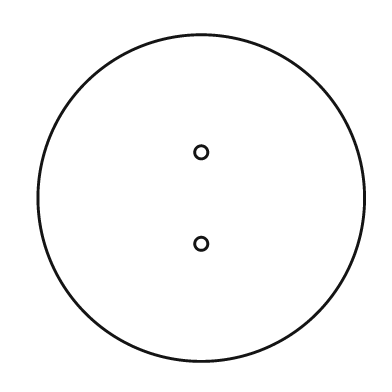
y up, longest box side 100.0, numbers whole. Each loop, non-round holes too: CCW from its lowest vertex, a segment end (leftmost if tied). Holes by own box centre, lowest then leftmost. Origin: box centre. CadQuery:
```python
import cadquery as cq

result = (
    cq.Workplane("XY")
    .moveTo(0.0, 0.0)
    .circle(50.0)
    .moveTo(0.0, -14.0)
    .circle(2.0)
    .moveTo(0.0, 14.0)
    .circle(2.0)
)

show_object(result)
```